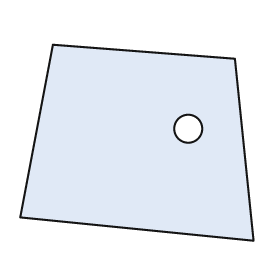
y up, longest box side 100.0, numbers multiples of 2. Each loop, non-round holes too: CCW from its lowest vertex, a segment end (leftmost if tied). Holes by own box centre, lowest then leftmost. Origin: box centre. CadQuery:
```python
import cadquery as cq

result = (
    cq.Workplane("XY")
    .moveTo(50.0, -42.0)
    .lineTo(42.0, 36.0)
    .lineTo(-36.0, 42.0)
    .lineTo(-50.0, -32.0)
    .close()
    .moveTo(22.0, 6.0)
    .circle(6.0)
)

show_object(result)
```